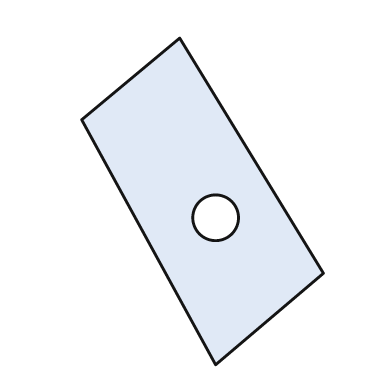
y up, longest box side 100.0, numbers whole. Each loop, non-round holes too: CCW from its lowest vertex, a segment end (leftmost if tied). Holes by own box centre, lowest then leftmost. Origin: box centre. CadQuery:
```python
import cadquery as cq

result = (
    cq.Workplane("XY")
    .moveTo(4.0, -50.0)
    .lineTo(37.0, -22.0)
    .lineTo(-7.0, 50.0)
    .lineTo(-37.0, 25.0)
    .close()
    .moveTo(4.0, -5.0)
    .circle(7.0)
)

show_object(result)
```